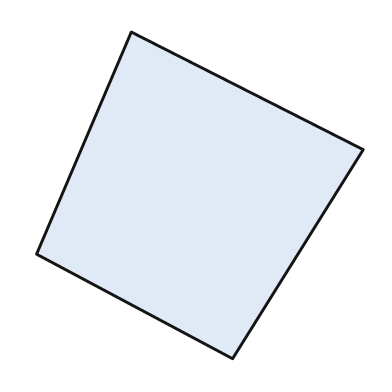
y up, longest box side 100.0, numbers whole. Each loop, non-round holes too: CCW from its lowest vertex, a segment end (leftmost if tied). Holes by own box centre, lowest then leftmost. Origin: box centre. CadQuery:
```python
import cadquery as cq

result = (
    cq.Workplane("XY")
    .moveTo(10.0, -50.0)
    .lineTo(50.0, 14.0)
    .lineTo(-21.0, 50.0)
    .lineTo(-50.0, -18.0)
    .close()
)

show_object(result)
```